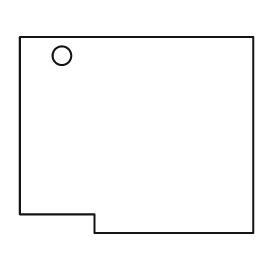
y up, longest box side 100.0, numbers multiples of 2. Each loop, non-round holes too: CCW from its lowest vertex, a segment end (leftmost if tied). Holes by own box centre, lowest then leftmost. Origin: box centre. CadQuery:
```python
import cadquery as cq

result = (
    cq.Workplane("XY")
    .moveTo(-18.0, -42.0)
    .lineTo(50.0, -42.0)
    .lineTo(50.0, 42.0)
    .lineTo(-50.0, 42.0)
    .lineTo(-50.0, -34.0)
    .lineTo(-18.0, -34.0)
    .close()
    .moveTo(-32.0, 34.0)
    .circle(4.0)
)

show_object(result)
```